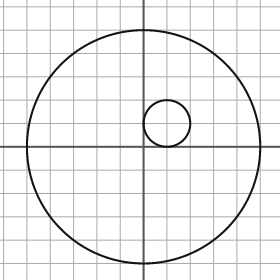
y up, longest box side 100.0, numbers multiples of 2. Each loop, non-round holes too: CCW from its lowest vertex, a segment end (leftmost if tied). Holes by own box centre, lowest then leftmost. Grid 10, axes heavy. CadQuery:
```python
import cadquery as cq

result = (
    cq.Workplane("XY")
    .moveTo(0.0, 0.0)
    .circle(50.0)
    .moveTo(10.0, 10.0)
    .circle(10.0)
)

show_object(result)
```